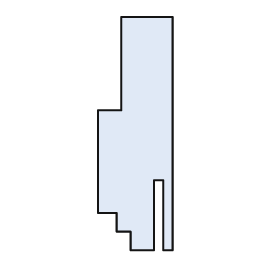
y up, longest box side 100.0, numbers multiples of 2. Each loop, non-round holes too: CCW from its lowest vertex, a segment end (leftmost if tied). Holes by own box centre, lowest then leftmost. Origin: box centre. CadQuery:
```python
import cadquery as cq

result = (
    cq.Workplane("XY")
    .moveTo(-2.0, -50.0)
    .lineTo(8.0, -50.0)
    .lineTo(8.0, -20.0)
    .lineTo(12.0, -20.0)
    .lineTo(12.0, -50.0)
    .lineTo(16.0, -50.0)
    .lineTo(16.0, 50.0)
    .lineTo(-6.0, 50.0)
    .lineTo(-6.0, 10.0)
    .lineTo(-16.0, 10.0)
    .lineTo(-16.0, -34.0)
    .lineTo(-8.0, -34.0)
    .lineTo(-8.0, -42.0)
    .lineTo(-2.0, -42.0)
    .close()
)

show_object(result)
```